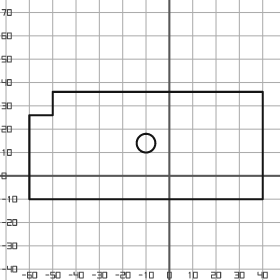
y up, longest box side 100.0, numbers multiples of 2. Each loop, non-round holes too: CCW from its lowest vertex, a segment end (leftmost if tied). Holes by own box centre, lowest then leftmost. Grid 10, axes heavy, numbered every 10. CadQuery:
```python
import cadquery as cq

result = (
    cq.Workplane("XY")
    .moveTo(-60.0, -10.0)
    .lineTo(40.0, -10.0)
    .lineTo(40.0, 36.0)
    .lineTo(-50.0, 36.0)
    .lineTo(-50.0, 26.0)
    .lineTo(-60.0, 26.0)
    .close()
    .moveTo(-10.0, 14.0)
    .circle(4.0)
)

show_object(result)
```